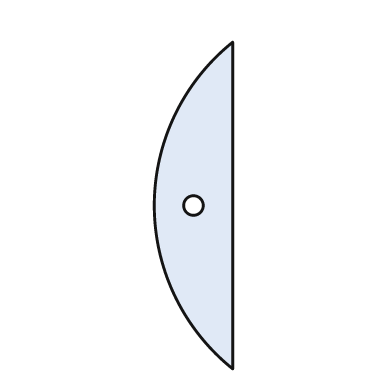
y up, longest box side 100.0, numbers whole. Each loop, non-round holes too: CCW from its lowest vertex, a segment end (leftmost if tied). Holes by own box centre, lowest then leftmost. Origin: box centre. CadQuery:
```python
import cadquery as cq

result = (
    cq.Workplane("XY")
    .moveTo(12.0, -50.0)
    .lineTo(12.0, 50.0)
    .threePointArc((-12.0, 0.0), (12.0, -50.0))
    .close()
    .moveTo(0.0, 0.0)
    .circle(3.0)
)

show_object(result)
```